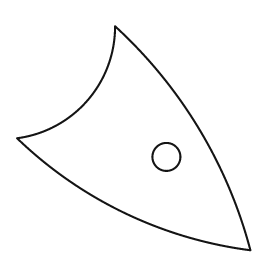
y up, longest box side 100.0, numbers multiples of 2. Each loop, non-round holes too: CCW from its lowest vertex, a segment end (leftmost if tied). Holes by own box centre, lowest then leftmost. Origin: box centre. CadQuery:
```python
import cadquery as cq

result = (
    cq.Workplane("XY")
    .moveTo(50.0, -48.0)
    .threePointArc((28.0, 4.0), (-8.0, 48.0))
    .threePointArc((-20.0, 16.0), (-50.0, 0.0))
    .threePointArc((-4.0, -32.0), (50.0, -48.0))
    .close()
    .moveTo(14.0, -8.0)
    .circle(6.0)
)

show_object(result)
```